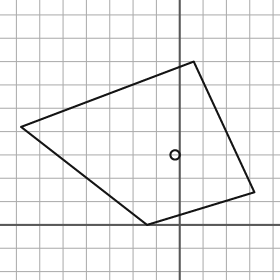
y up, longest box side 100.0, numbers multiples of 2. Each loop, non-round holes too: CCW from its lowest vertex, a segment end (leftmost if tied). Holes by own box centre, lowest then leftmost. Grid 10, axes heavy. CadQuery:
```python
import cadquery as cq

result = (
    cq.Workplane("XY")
    .moveTo(-14.0, 0.0)
    .lineTo(32.0, 14.0)
    .lineTo(6.0, 70.0)
    .lineTo(-68.0, 42.0)
    .close()
    .moveTo(-2.0, 30.0)
    .circle(2.0)
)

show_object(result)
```